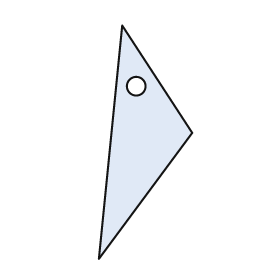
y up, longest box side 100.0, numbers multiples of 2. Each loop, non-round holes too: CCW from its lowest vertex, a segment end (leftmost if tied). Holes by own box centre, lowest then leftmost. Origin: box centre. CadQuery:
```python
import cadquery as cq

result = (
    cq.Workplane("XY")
    .moveTo(-20.0, -50.0)
    .lineTo(20.0, 4.0)
    .lineTo(-10.0, 50.0)
    .close()
    .moveTo(-4.0, 24.0)
    .circle(4.0)
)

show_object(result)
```